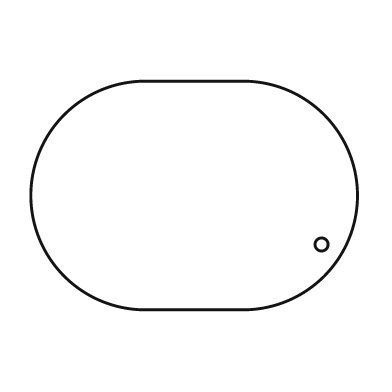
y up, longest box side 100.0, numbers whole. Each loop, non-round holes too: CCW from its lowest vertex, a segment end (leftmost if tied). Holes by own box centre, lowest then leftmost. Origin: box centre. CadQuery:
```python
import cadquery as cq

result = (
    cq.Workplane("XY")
    .moveTo(-15.0, -35.0)
    .lineTo(15.0, -35.0)
    .threePointArc((50.0, 0.0), (15.0, 35.0))
    .lineTo(-15.0, 35.0)
    .threePointArc((-50.0, 0.0), (-15.0, -35.0))
    .close()
    .moveTo(39.0, -15.0)
    .circle(2.0)
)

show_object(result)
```